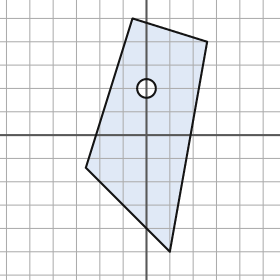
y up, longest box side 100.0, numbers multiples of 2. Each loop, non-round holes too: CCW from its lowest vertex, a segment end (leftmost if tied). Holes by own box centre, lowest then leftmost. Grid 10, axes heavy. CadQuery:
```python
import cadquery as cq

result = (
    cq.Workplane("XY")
    .moveTo(10.0, -50.0)
    .lineTo(26.0, 40.0)
    .lineTo(-6.0, 50.0)
    .lineTo(-26.0, -14.0)
    .close()
    .moveTo(0.0, 20.0)
    .circle(4.0)
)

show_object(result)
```